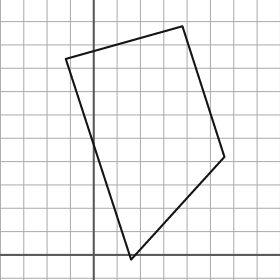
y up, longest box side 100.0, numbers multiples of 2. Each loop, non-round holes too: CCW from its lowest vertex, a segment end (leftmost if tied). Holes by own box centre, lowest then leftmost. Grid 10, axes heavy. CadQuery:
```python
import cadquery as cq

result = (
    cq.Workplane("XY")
    .moveTo(16.0, -2.0)
    .lineTo(56.0, 42.0)
    .lineTo(38.0, 98.0)
    .lineTo(-12.0, 84.0)
    .close()
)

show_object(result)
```